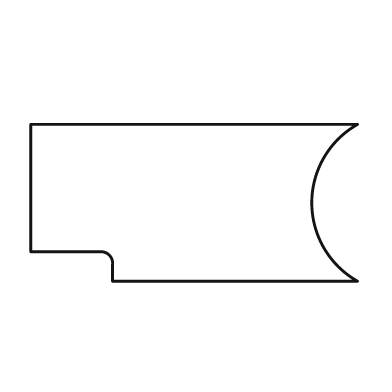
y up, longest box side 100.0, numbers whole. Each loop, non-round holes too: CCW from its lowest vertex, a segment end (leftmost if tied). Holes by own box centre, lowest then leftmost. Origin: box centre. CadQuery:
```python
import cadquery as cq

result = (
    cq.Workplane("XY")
    .moveTo(-25.0, -24.0)
    .lineTo(50.0, -24.0)
    .threePointArc((36.0, 0.0), (50.0, 24.0))
    .lineTo(-50.0, 24.0)
    .lineTo(-50.0, -15.0)
    .lineTo(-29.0, -15.0)
    .threePointArc((-26.0, -16.0), (-25.0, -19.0))
    .close()
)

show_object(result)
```